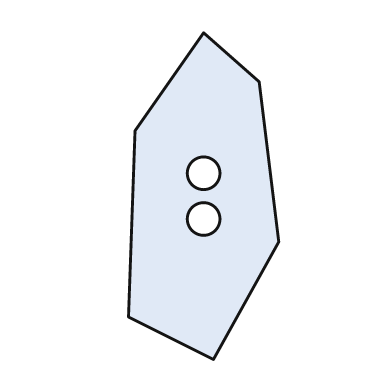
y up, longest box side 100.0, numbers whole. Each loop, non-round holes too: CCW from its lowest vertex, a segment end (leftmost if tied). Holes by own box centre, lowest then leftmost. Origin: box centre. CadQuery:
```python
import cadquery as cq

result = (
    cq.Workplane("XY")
    .moveTo(3.0, -50.0)
    .lineTo(23.0, -14.0)
    .lineTo(17.0, 35.0)
    .lineTo(0.0, 50.0)
    .lineTo(-21.0, 20.0)
    .lineTo(-23.0, -37.0)
    .close()
    .moveTo(0.0, -7.0)
    .circle(5.0)
    .moveTo(0.0, 7.0)
    .circle(5.0)
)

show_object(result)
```